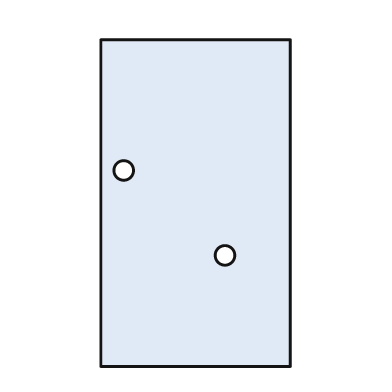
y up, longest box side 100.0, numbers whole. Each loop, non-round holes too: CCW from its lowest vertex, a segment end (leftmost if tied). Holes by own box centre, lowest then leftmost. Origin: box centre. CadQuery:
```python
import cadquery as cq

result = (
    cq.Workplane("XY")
    .moveTo(-29.0, -50.0)
    .lineTo(29.0, -50.0)
    .lineTo(29.0, 50.0)
    .lineTo(-29.0, 50.0)
    .close()
    .moveTo(9.0, -16.0)
    .circle(3.0)
    .moveTo(-22.0, 10.0)
    .circle(3.0)
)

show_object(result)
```